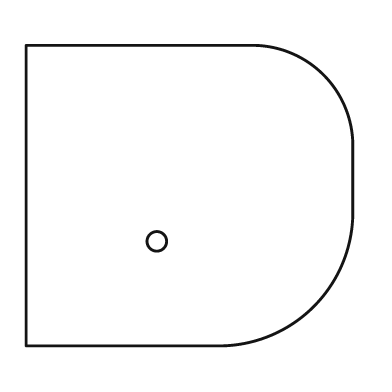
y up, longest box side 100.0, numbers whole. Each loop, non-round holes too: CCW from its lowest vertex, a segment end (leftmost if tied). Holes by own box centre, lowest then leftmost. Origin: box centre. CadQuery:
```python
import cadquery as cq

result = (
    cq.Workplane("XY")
    .moveTo(-50.0, -46.0)
    .lineTo(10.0, -46.0)
    .threePointArc((38.0, -34.0), (50.0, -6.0))
    .lineTo(50.0, 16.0)
    .threePointArc((41.0, 37.0), (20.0, 46.0))
    .lineTo(-50.0, 46.0)
    .close()
    .moveTo(-10.0, -14.0)
    .circle(3.0)
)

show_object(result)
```